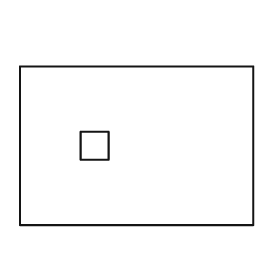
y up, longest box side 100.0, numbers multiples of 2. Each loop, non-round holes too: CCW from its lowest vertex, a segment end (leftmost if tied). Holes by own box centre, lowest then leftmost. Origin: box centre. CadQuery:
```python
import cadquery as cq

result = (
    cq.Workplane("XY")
    .moveTo(-50.0, -34.0)
    .lineTo(50.0, -34.0)
    .lineTo(50.0, 34.0)
    .lineTo(-50.0, 34.0)
    .close()
    .moveTo(-24.0, -6.0)
    .lineTo(-12.0, -6.0)
    .lineTo(-12.0, 6.0)
    .lineTo(-24.0, 6.0)
    .close()
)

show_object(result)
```